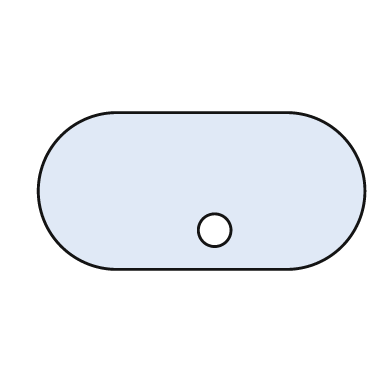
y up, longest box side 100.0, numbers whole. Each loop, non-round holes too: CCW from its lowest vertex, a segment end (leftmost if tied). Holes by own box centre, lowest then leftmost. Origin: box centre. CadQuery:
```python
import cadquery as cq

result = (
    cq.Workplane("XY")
    .moveTo(-26.0, -24.0)
    .lineTo(26.0, -24.0)
    .threePointArc((50.0, 0.0), (26.0, 24.0))
    .lineTo(-26.0, 24.0)
    .threePointArc((-50.0, 0.0), (-26.0, -24.0))
    .close()
    .moveTo(4.0, -12.0)
    .circle(5.0)
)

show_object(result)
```